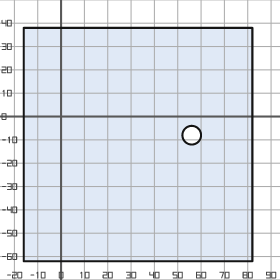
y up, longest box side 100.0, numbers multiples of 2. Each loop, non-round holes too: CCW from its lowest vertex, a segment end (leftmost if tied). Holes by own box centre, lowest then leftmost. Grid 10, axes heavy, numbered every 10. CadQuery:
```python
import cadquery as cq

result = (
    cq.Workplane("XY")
    .moveTo(-16.0, -62.0)
    .lineTo(82.0, -62.0)
    .lineTo(82.0, 38.0)
    .lineTo(-16.0, 38.0)
    .close()
    .moveTo(56.0, -8.0)
    .circle(4.0)
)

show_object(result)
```